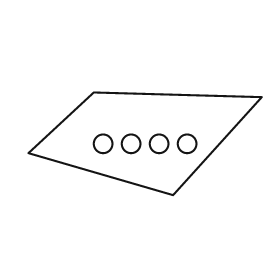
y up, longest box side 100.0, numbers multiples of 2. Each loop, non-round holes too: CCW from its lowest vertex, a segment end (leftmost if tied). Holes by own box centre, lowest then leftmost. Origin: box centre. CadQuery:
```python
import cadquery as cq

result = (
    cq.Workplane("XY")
    .moveTo(12.0, -22.0)
    .lineTo(50.0, 20.0)
    .lineTo(-22.0, 22.0)
    .lineTo(-50.0, -4.0)
    .close()
    .moveTo(-18.0, 0.0)
    .circle(4.0)
    .moveTo(-6.0, 0.0)
    .circle(4.0)
    .moveTo(6.0, 0.0)
    .circle(4.0)
    .moveTo(18.0, 0.0)
    .circle(4.0)
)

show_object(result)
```